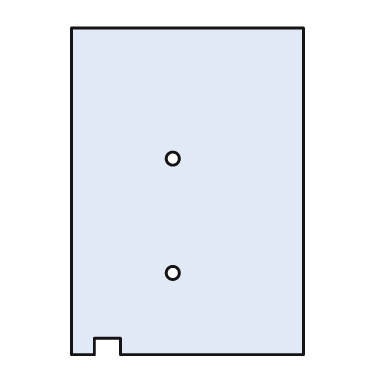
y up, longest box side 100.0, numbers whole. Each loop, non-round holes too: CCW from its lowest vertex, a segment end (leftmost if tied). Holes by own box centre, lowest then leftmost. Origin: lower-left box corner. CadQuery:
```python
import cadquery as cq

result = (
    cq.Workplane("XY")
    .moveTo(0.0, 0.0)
    .lineTo(7.0, 0.0)
    .lineTo(7.0, 5.0)
    .lineTo(15.0, 5.0)
    .lineTo(15.0, 0.0)
    .lineTo(71.0, 0.0)
    .lineTo(71.0, 100.0)
    .lineTo(0.0, 100.0)
    .close()
    .moveTo(31.0, 25.0)
    .circle(2.0)
    .moveTo(31.0, 60.0)
    .circle(2.0)
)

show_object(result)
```